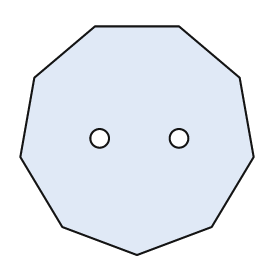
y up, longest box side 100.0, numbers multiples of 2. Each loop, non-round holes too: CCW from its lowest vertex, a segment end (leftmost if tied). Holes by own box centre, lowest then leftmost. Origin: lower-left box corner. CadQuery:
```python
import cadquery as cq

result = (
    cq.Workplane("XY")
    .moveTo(50.0, 0.0)
    .lineTo(82.0, 12.0)
    .lineTo(100.0, 42.0)
    .lineTo(94.0, 76.0)
    .lineTo(68.0, 98.0)
    .lineTo(32.0, 98.0)
    .lineTo(6.0, 76.0)
    .lineTo(0.0, 42.0)
    .lineTo(18.0, 12.0)
    .close()
    .moveTo(34.0, 50.0)
    .circle(4.0)
    .moveTo(68.0, 50.0)
    .circle(4.0)
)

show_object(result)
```